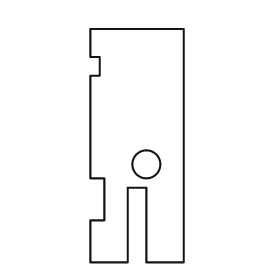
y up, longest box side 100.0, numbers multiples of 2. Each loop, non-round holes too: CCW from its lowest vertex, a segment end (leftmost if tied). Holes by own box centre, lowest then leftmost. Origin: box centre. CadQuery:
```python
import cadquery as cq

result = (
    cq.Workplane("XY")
    .moveTo(-20.0, -50.0)
    .lineTo(-4.0, -50.0)
    .lineTo(-4.0, -18.0)
    .lineTo(4.0, -18.0)
    .lineTo(4.0, -50.0)
    .lineTo(20.0, -50.0)
    .lineTo(20.0, 50.0)
    .lineTo(-20.0, 50.0)
    .lineTo(-20.0, 38.0)
    .lineTo(-16.0, 38.0)
    .lineTo(-16.0, 30.0)
    .lineTo(-20.0, 30.0)
    .lineTo(-20.0, -14.0)
    .lineTo(-14.0, -14.0)
    .lineTo(-14.0, -32.0)
    .lineTo(-20.0, -32.0)
    .close()
    .moveTo(4.0, -8.0)
    .circle(6.0)
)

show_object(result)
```